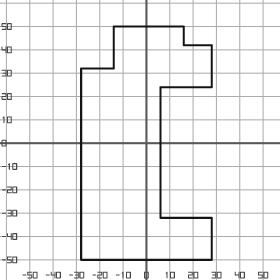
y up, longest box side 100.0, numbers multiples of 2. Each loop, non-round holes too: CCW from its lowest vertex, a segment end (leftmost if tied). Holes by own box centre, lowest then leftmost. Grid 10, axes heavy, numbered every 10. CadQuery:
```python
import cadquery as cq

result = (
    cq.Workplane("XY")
    .moveTo(-28.0, -50.0)
    .lineTo(28.0, -50.0)
    .lineTo(28.0, -32.0)
    .lineTo(6.0, -32.0)
    .lineTo(6.0, 24.0)
    .lineTo(28.0, 24.0)
    .lineTo(28.0, 42.0)
    .lineTo(16.0, 42.0)
    .lineTo(16.0, 50.0)
    .lineTo(-14.0, 50.0)
    .lineTo(-14.0, 32.0)
    .lineTo(-28.0, 32.0)
    .close()
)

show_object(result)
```